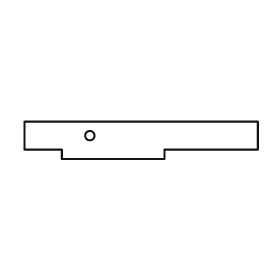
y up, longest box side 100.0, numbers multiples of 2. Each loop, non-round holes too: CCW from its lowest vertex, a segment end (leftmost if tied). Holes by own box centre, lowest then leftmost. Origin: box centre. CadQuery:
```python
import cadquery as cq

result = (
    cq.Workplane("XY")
    .moveTo(-34.0, -8.0)
    .lineTo(10.0, -8.0)
    .lineTo(10.0, -4.0)
    .lineTo(50.0, -4.0)
    .lineTo(50.0, 8.0)
    .lineTo(-50.0, 8.0)
    .lineTo(-50.0, -4.0)
    .lineTo(-34.0, -4.0)
    .close()
    .moveTo(-22.0, 2.0)
    .circle(2.0)
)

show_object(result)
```